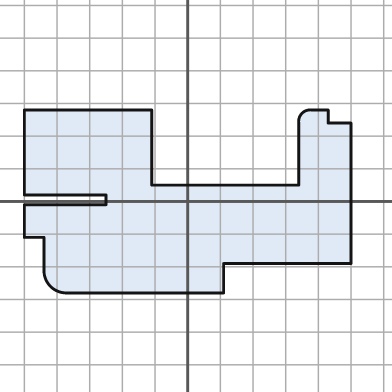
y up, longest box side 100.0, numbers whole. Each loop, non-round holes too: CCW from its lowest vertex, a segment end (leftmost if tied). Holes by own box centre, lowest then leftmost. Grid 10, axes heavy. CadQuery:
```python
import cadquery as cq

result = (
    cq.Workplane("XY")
    .moveTo(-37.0, -28.0)
    .lineTo(11.0, -28.0)
    .lineTo(11.0, -19.0)
    .lineTo(50.0, -19.0)
    .lineTo(50.0, 24.0)
    .lineTo(43.0, 24.0)
    .lineTo(43.0, 28.0)
    .lineTo(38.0, 28.0)
    .threePointArc((35.0, 27.0), (34.0, 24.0))
    .lineTo(34.0, 5.0)
    .lineTo(-11.0, 5.0)
    .lineTo(-11.0, 28.0)
    .lineTo(-50.0, 28.0)
    .lineTo(-50.0, 2.0)
    .lineTo(-25.0, 2.0)
    .lineTo(-25.0, -1.0)
    .lineTo(-50.0, -1.0)
    .lineTo(-50.0, -11.0)
    .lineTo(-44.0, -11.0)
    .lineTo(-44.0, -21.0)
    .threePointArc((-42.0, -26.0), (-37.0, -28.0))
    .close()
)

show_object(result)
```